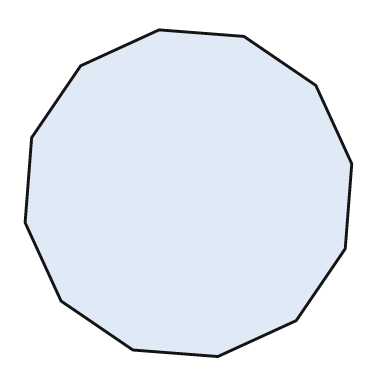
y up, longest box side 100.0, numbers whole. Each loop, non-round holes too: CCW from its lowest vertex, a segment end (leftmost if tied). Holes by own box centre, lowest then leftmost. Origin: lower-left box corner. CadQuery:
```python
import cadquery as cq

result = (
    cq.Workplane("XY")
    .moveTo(59.0, 0.0)
    .lineTo(83.0, 11.0)
    .lineTo(98.0, 33.0)
    .lineTo(100.0, 59.0)
    .lineTo(89.0, 83.0)
    .lineTo(67.0, 98.0)
    .lineTo(41.0, 100.0)
    .lineTo(17.0, 89.0)
    .lineTo(2.0, 67.0)
    .lineTo(0.0, 41.0)
    .lineTo(11.0, 17.0)
    .lineTo(33.0, 2.0)
    .close()
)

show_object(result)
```